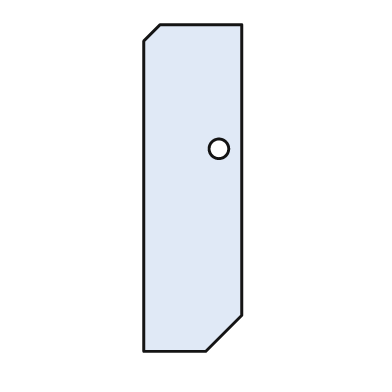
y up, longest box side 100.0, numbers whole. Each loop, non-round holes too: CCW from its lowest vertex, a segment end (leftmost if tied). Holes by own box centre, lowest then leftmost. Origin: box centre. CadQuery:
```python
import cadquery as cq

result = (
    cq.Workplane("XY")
    .moveTo(-15.0, -50.0)
    .lineTo(4.0, -50.0)
    .lineTo(15.0, -39.0)
    .lineTo(15.0, 50.0)
    .lineTo(-10.0, 50.0)
    .lineTo(-15.0, 45.0)
    .close()
    .moveTo(8.0, 12.0)
    .circle(3.0)
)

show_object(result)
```